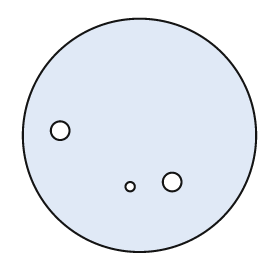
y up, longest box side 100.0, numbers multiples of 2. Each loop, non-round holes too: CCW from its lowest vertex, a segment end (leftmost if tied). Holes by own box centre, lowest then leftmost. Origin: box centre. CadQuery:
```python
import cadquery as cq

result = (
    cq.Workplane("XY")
    .moveTo(0.0, 0.0)
    .circle(50.0)
    .moveTo(-4.0, -22.0)
    .circle(2.0)
    .moveTo(14.0, -20.0)
    .circle(4.0)
    .moveTo(-34.0, 2.0)
    .circle(4.0)
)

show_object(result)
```